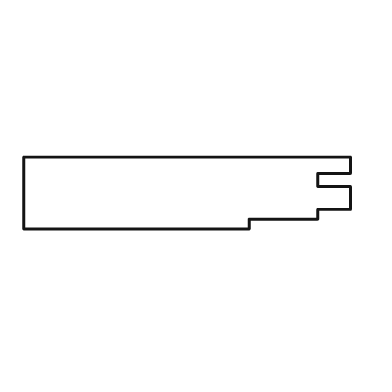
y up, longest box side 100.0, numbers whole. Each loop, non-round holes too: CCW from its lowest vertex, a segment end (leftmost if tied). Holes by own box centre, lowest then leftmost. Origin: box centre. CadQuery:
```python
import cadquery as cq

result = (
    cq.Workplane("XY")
    .moveTo(-50.0, -11.0)
    .lineTo(19.0, -11.0)
    .lineTo(19.0, -8.0)
    .lineTo(40.0, -8.0)
    .lineTo(40.0, -5.0)
    .lineTo(50.0, -5.0)
    .lineTo(50.0, 2.0)
    .lineTo(40.0, 2.0)
    .lineTo(40.0, 6.0)
    .lineTo(50.0, 6.0)
    .lineTo(50.0, 11.0)
    .lineTo(-50.0, 11.0)
    .close()
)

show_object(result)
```